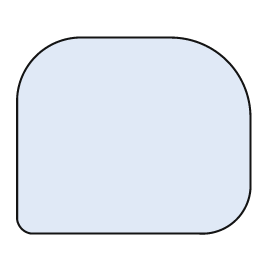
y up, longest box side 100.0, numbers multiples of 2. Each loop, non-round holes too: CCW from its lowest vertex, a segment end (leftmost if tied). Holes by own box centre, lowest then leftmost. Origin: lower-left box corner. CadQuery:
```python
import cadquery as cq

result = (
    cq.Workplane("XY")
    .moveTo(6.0, 0.0)
    .lineTo(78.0, 0.0)
    .threePointArc((94.0, 6.0), (100.0, 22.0))
    .lineTo(100.0, 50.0)
    .threePointArc((90.0, 74.0), (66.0, 84.0))
    .lineTo(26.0, 84.0)
    .threePointArc((8.0, 76.0), (0.0, 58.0))
    .lineTo(0.0, 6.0)
    .threePointArc((2.0, 2.0), (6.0, 0.0))
    .close()
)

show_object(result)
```